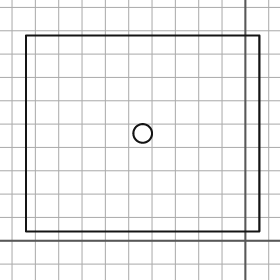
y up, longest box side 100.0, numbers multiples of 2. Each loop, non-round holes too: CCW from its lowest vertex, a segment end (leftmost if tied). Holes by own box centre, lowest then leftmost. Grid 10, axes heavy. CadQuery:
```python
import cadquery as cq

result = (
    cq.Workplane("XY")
    .moveTo(-94.0, 4.0)
    .lineTo(6.0, 4.0)
    .lineTo(6.0, 88.0)
    .lineTo(-94.0, 88.0)
    .close()
    .moveTo(-44.0, 46.0)
    .circle(4.0)
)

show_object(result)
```